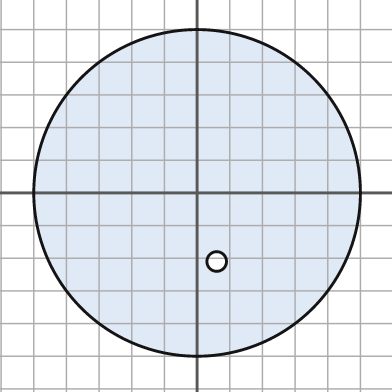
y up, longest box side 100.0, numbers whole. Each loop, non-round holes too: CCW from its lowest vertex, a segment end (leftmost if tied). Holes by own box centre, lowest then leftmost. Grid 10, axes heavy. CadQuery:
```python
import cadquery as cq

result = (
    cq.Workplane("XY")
    .moveTo(0.0, 0.0)
    .circle(50.0)
    .moveTo(6.0, -21.0)
    .circle(3.0)
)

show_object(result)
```